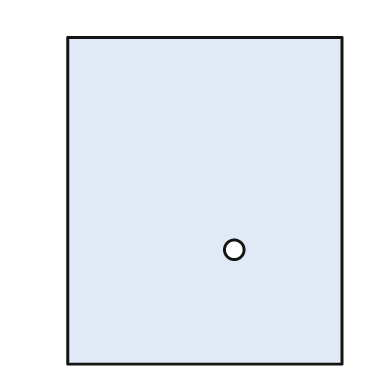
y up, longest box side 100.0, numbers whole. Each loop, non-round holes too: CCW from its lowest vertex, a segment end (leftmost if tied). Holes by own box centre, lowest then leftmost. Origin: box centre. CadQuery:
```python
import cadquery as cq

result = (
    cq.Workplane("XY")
    .moveTo(-42.0, -50.0)
    .lineTo(42.0, -50.0)
    .lineTo(42.0, 50.0)
    .lineTo(-42.0, 50.0)
    .close()
    .moveTo(9.0, -15.0)
    .circle(3.0)
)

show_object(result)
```